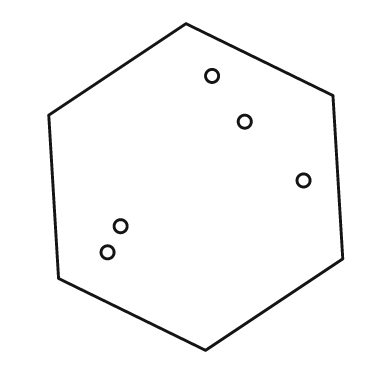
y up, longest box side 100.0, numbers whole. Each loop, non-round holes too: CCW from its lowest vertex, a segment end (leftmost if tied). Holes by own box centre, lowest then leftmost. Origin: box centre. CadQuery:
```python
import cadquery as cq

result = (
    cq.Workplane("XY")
    .moveTo(3.0, -50.0)
    .lineTo(45.0, -22.0)
    .lineTo(42.0, 28.0)
    .lineTo(-3.0, 50.0)
    .lineTo(-45.0, 22.0)
    .lineTo(-42.0, -28.0)
    .close()
    .moveTo(-27.0, -20.0)
    .circle(2.0)
    .moveTo(-23.0, -12.0)
    .circle(2.0)
    .moveTo(33.0, 2.0)
    .circle(2.0)
    .moveTo(15.0, 20.0)
    .circle(2.0)
    .moveTo(5.0, 34.0)
    .circle(2.0)
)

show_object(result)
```